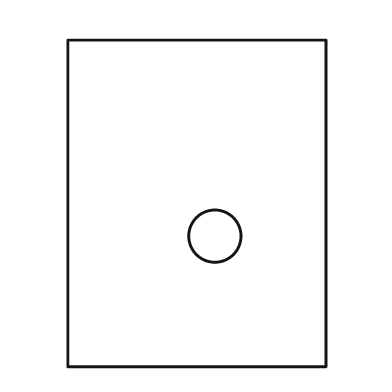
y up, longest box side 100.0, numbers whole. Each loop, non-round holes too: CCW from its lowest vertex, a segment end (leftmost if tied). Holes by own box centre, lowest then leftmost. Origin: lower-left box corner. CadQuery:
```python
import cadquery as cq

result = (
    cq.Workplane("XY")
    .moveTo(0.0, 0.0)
    .lineTo(79.0, 0.0)
    .lineTo(79.0, 100.0)
    .lineTo(0.0, 100.0)
    .close()
    .moveTo(45.0, 40.0)
    .circle(8.0)
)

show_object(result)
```